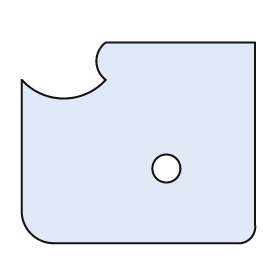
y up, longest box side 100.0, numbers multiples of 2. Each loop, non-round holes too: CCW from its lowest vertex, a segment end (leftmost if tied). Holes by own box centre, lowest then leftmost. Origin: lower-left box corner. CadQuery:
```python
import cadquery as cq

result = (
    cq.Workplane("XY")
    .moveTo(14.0, 0.0)
    .lineTo(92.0, 0.0)
    .threePointArc((98.0, 2.0), (100.0, 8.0))
    .lineTo(100.0, 86.0)
    .lineTo(36.0, 86.0)
    .threePointArc((32.0, 78.0), (36.0, 70.0))
    .threePointArc((18.0, 62.0), (0.0, 70.0))
    .lineTo(0.0, 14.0)
    .threePointArc((4.0, 4.0), (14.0, 0.0))
    .close()
    .moveTo(62.0, 32.0)
    .circle(6.0)
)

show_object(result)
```